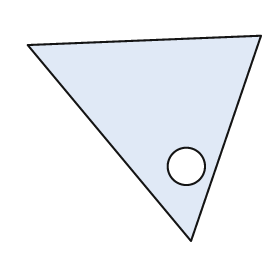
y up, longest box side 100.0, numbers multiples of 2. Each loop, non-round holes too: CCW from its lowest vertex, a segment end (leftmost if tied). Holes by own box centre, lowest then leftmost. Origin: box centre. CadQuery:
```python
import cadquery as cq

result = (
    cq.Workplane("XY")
    .moveTo(20.0, -44.0)
    .lineTo(50.0, 44.0)
    .lineTo(-50.0, 40.0)
    .close()
    .moveTo(18.0, -12.0)
    .circle(8.0)
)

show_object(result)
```